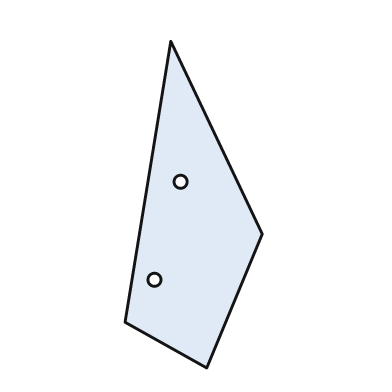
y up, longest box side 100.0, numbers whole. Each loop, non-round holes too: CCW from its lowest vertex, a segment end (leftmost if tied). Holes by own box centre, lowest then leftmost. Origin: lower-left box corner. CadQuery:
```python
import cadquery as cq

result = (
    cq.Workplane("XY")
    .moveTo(25.0, 0.0)
    .lineTo(42.0, 41.0)
    .lineTo(14.0, 100.0)
    .lineTo(0.0, 14.0)
    .close()
    .moveTo(9.0, 27.0)
    .circle(2.0)
    .moveTo(17.0, 57.0)
    .circle(2.0)
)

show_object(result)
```